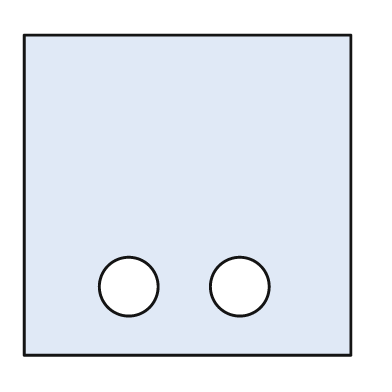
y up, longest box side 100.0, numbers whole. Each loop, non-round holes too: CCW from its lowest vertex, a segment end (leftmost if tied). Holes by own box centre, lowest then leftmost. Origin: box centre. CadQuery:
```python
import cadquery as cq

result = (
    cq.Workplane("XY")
    .moveTo(-50.0, -49.0)
    .lineTo(50.0, -49.0)
    .lineTo(50.0, 49.0)
    .lineTo(-50.0, 49.0)
    .close()
    .moveTo(-18.0, -28.0)
    .circle(9.0)
    .moveTo(16.0, -28.0)
    .circle(9.0)
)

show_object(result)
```